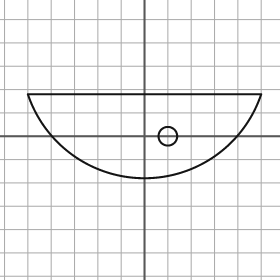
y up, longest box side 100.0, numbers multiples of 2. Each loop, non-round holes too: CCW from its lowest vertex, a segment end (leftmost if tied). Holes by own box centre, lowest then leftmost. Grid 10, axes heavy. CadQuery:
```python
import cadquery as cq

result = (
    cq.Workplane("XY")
    .moveTo(-50.0, 18.0)
    .threePointArc((0.0, -18.0), (50.0, 18.0))
    .close()
    .moveTo(10.0, 0.0)
    .circle(4.0)
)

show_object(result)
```